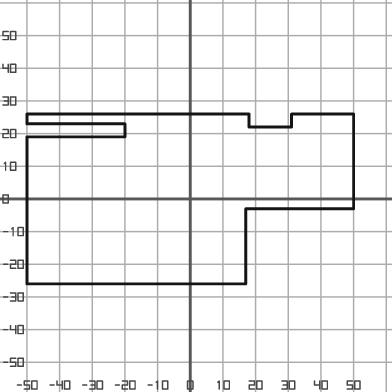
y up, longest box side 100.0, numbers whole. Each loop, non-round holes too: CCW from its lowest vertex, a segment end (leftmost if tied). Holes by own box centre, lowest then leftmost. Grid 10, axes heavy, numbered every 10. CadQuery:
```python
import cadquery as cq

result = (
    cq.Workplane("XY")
    .moveTo(-50.0, -26.0)
    .lineTo(17.0, -26.0)
    .lineTo(17.0, -3.0)
    .lineTo(50.0, -3.0)
    .lineTo(50.0, 26.0)
    .lineTo(31.0, 26.0)
    .lineTo(31.0, 22.0)
    .lineTo(18.0, 22.0)
    .lineTo(18.0, 26.0)
    .lineTo(-50.0, 26.0)
    .lineTo(-50.0, 23.0)
    .lineTo(-20.0, 23.0)
    .lineTo(-20.0, 19.0)
    .lineTo(-50.0, 19.0)
    .close()
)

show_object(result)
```